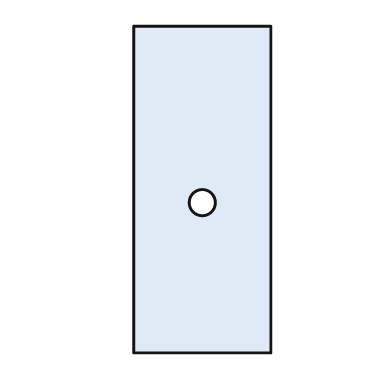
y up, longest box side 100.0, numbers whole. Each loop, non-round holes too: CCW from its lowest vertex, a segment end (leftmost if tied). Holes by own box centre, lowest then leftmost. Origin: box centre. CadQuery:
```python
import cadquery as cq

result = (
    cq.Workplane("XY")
    .moveTo(-21.0, -50.0)
    .lineTo(21.0, -50.0)
    .lineTo(21.0, 50.0)
    .lineTo(-21.0, 50.0)
    .close()
    .moveTo(0.0, -4.0)
    .circle(4.0)
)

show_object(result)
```